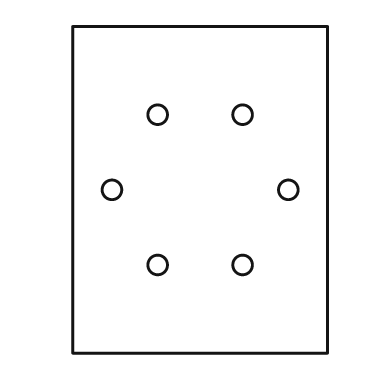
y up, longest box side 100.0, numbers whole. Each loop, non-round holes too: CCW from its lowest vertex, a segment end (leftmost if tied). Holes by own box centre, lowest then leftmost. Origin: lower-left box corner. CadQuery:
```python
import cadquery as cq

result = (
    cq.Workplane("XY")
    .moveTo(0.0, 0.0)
    .lineTo(78.0, 0.0)
    .lineTo(78.0, 100.0)
    .lineTo(0.0, 100.0)
    .close()
    .moveTo(26.0, 27.0)
    .circle(3.0)
    .moveTo(52.0, 27.0)
    .circle(3.0)
    .moveTo(12.0, 50.0)
    .circle(3.0)
    .moveTo(66.0, 50.0)
    .circle(3.0)
    .moveTo(26.0, 73.0)
    .circle(3.0)
    .moveTo(52.0, 73.0)
    .circle(3.0)
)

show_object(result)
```